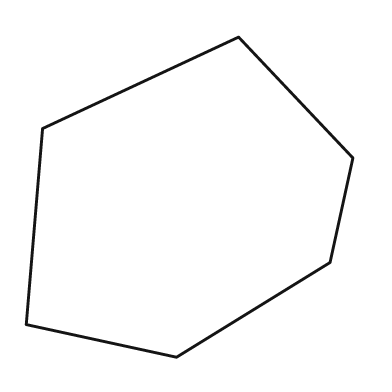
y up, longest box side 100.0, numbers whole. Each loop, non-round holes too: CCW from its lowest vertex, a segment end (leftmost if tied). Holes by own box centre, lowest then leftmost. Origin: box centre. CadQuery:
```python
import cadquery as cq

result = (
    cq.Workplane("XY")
    .moveTo(-4.0, -49.0)
    .lineTo(43.0, -20.0)
    .lineTo(50.0, 12.0)
    .lineTo(15.0, 49.0)
    .lineTo(-45.0, 21.0)
    .lineTo(-50.0, -39.0)
    .close()
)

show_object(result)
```